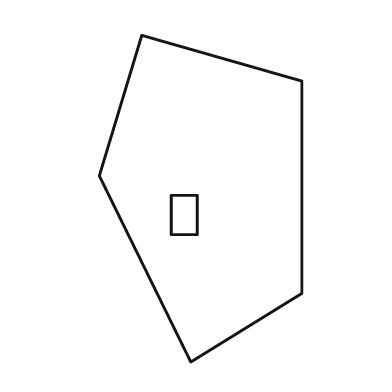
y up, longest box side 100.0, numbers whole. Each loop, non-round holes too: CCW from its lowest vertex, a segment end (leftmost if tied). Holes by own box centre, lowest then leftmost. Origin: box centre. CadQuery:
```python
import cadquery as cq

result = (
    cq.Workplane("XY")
    .moveTo(-3.0, -50.0)
    .lineTo(31.0, -29.0)
    .lineTo(31.0, 36.0)
    .lineTo(-18.0, 50.0)
    .lineTo(-31.0, 7.0)
    .close()
    .moveTo(-9.0, -11.0)
    .lineTo(-1.0, -11.0)
    .lineTo(-1.0, 1.0)
    .lineTo(-9.0, 1.0)
    .close()
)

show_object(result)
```